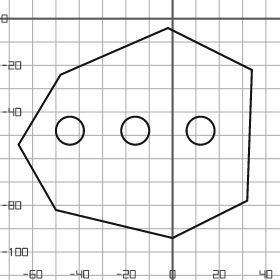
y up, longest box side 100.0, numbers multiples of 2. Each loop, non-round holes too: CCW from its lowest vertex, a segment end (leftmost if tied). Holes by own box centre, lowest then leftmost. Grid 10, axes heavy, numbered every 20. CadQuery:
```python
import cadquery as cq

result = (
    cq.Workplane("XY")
    .moveTo(0.0, -94.0)
    .lineTo(32.0, -78.0)
    .lineTo(34.0, -22.0)
    .lineTo(-2.0, -4.0)
    .lineTo(-48.0, -24.0)
    .lineTo(-66.0, -54.0)
    .lineTo(-50.0, -82.0)
    .close()
    .moveTo(-44.0, -48.0)
    .circle(6.0)
    .moveTo(-16.0, -48.0)
    .circle(6.0)
    .moveTo(12.0, -48.0)
    .circle(6.0)
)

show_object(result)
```